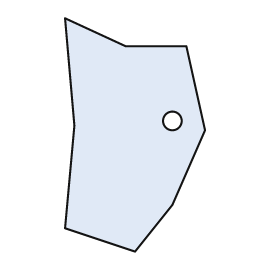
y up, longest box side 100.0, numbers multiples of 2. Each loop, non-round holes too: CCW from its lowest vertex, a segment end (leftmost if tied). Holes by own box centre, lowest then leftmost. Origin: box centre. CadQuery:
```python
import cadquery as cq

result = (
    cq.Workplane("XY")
    .moveTo(0.0, -50.0)
    .lineTo(16.0, -30.0)
    .lineTo(30.0, 2.0)
    .lineTo(22.0, 38.0)
    .lineTo(-4.0, 38.0)
    .lineTo(-30.0, 50.0)
    .lineTo(-26.0, 4.0)
    .lineTo(-30.0, -40.0)
    .close()
    .moveTo(16.0, 6.0)
    .circle(4.0)
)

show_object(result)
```